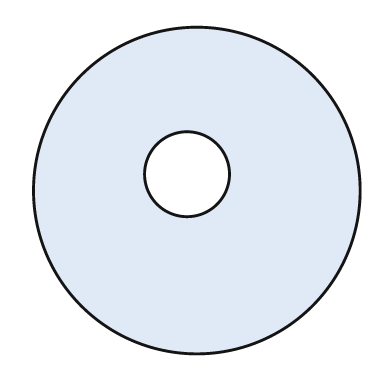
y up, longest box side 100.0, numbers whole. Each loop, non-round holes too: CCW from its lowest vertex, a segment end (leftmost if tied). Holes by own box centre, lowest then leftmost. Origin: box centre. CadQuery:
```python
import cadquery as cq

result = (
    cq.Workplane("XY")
    .moveTo(0.0, 0.0)
    .circle(50.0)
    .moveTo(-3.0, 5.0)
    .circle(13.0)
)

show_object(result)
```